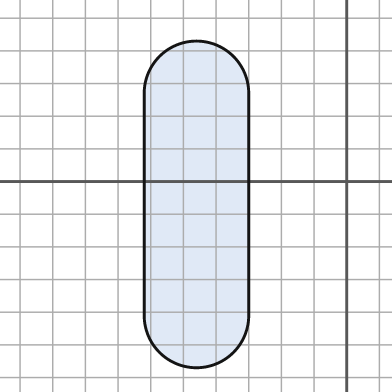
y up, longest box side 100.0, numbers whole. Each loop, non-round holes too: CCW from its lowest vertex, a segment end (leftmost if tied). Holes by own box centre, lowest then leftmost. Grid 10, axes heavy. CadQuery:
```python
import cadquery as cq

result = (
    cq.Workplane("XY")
    .moveTo(-62.0, -41.0)
    .threePointArc((-46.0, -57.0), (-30.0, -41.0))
    .lineTo(-30.0, 27.0)
    .threePointArc((-46.0, 43.0), (-62.0, 27.0))
    .close()
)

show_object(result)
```